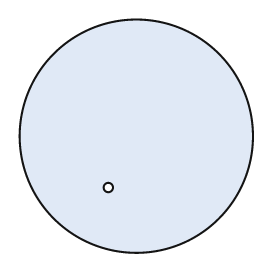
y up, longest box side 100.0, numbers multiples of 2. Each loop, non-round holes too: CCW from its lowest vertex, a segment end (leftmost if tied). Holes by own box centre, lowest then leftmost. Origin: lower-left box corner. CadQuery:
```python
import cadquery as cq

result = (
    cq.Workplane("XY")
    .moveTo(50.0, 50.0)
    .circle(50.0)
    .moveTo(38.0, 28.0)
    .circle(2.0)
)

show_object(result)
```